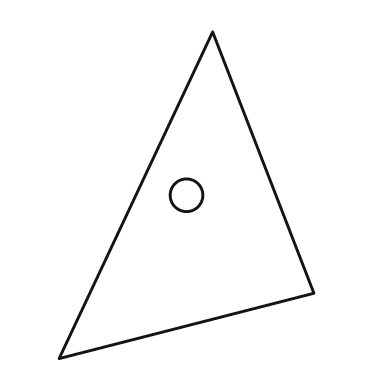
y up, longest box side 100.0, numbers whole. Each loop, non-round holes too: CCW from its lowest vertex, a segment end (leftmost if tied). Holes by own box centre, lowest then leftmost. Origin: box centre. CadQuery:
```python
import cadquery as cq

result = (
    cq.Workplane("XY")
    .moveTo(-39.0, -50.0)
    .lineTo(39.0, -30.0)
    .lineTo(8.0, 50.0)
    .close()
    .moveTo(0.0, 0.0)
    .circle(5.0)
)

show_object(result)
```